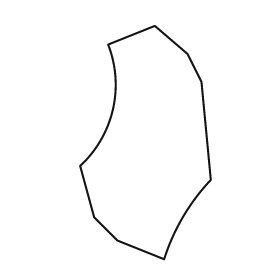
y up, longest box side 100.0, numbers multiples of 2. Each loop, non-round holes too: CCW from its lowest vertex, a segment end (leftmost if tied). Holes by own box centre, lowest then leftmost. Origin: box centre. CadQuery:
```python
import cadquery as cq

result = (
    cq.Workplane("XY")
    .moveTo(8.0, -50.0)
    .threePointArc((16.0, -32.0), (28.0, -16.0))
    .lineTo(24.0, 26.0)
    .lineTo(18.0, 38.0)
    .lineTo(4.0, 50.0)
    .lineTo(-16.0, 42.0)
    .threePointArc((-14.0, 14.0), (-28.0, -10.0))
    .lineTo(-22.0, -32.0)
    .lineTo(-12.0, -42.0)
    .close()
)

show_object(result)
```